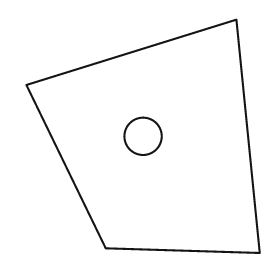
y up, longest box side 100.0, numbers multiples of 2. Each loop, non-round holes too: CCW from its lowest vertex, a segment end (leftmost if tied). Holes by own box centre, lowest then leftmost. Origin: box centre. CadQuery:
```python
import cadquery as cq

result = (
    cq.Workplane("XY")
    .moveTo(50.0, -50.0)
    .lineTo(40.0, 50.0)
    .lineTo(-50.0, 22.0)
    .lineTo(-16.0, -48.0)
    .close()
    .moveTo(0.0, 0.0)
    .circle(8.0)
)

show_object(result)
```